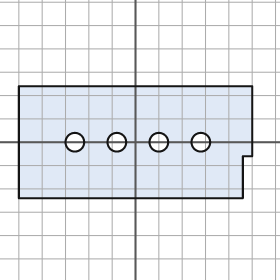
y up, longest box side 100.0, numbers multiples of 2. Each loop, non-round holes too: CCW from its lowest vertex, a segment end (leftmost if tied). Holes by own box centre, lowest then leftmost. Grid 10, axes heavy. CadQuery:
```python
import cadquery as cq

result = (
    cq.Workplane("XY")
    .moveTo(-50.0, -24.0)
    .lineTo(46.0, -24.0)
    .lineTo(46.0, -6.0)
    .lineTo(50.0, -6.0)
    .lineTo(50.0, 24.0)
    .lineTo(-50.0, 24.0)
    .close()
    .moveTo(-26.0, 0.0)
    .circle(4.0)
    .moveTo(-8.0, 0.0)
    .circle(4.0)
    .moveTo(10.0, 0.0)
    .circle(4.0)
    .moveTo(28.0, 0.0)
    .circle(4.0)
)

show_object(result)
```